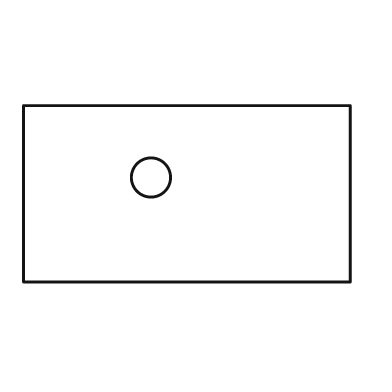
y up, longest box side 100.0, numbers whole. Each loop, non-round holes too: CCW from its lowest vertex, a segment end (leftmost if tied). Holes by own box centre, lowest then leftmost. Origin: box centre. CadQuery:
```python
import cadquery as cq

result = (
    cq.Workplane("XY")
    .moveTo(-50.0, -27.0)
    .lineTo(50.0, -27.0)
    .lineTo(50.0, 27.0)
    .lineTo(-50.0, 27.0)
    .close()
    .moveTo(-11.0, 5.0)
    .circle(6.0)
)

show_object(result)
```